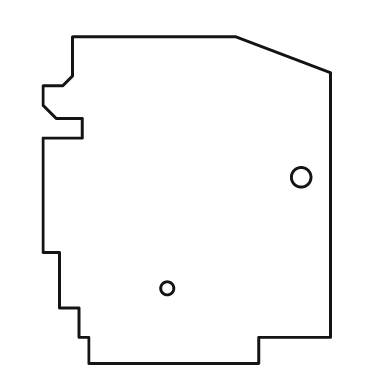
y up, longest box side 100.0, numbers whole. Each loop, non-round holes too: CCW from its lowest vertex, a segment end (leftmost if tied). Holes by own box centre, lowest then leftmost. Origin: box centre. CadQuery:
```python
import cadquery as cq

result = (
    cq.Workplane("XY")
    .moveTo(-30.0, -50.0)
    .lineTo(22.0, -50.0)
    .lineTo(22.0, -42.0)
    .lineTo(44.0, -42.0)
    .lineTo(44.0, 39.0)
    .lineTo(15.0, 50.0)
    .lineTo(-35.0, 50.0)
    .lineTo(-35.0, 38.0)
    .lineTo(-38.0, 35.0)
    .lineTo(-44.0, 35.0)
    .lineTo(-44.0, 29.0)
    .lineTo(-40.0, 25.0)
    .lineTo(-32.0, 25.0)
    .lineTo(-32.0, 19.0)
    .lineTo(-44.0, 19.0)
    .lineTo(-44.0, -16.0)
    .lineTo(-39.0, -16.0)
    .lineTo(-39.0, -33.0)
    .lineTo(-33.0, -33.0)
    .lineTo(-33.0, -42.0)
    .lineTo(-30.0, -42.0)
    .close()
    .moveTo(-6.0, -27.0)
    .circle(2.0)
    .moveTo(35.0, 7.0)
    .circle(3.0)
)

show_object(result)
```